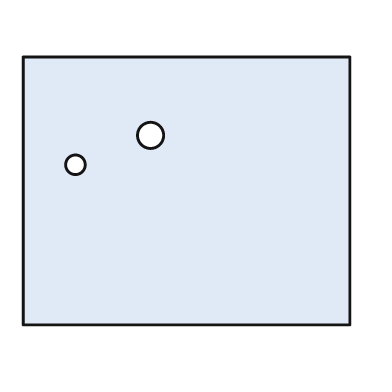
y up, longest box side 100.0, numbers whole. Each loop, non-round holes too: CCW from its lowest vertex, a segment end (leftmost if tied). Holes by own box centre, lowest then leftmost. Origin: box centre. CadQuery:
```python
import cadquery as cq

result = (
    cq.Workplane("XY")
    .moveTo(-50.0, -41.0)
    .lineTo(50.0, -41.0)
    .lineTo(50.0, 41.0)
    .lineTo(-50.0, 41.0)
    .close()
    .moveTo(-34.0, 8.0)
    .circle(3.0)
    .moveTo(-11.0, 17.0)
    .circle(4.0)
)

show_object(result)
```